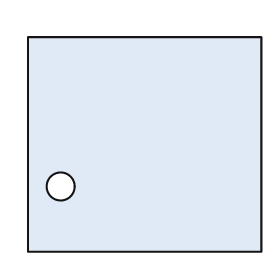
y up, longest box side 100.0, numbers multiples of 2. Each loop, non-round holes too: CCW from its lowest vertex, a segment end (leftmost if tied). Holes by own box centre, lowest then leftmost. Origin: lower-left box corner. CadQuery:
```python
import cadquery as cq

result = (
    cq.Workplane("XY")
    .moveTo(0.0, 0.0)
    .lineTo(100.0, 0.0)
    .lineTo(100.0, 92.0)
    .lineTo(0.0, 92.0)
    .close()
    .moveTo(14.0, 28.0)
    .circle(6.0)
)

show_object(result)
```